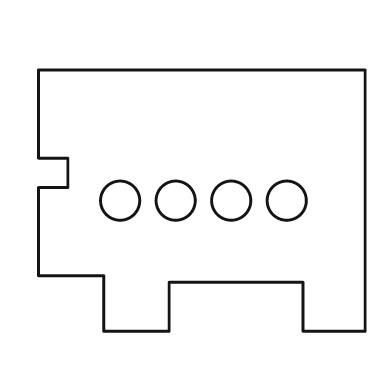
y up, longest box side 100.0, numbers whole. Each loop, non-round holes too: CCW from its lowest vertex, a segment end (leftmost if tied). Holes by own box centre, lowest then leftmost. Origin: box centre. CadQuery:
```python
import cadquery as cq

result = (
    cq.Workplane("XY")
    .moveTo(-30.0, -40.0)
    .lineTo(-10.0, -40.0)
    .lineTo(-10.0, -25.0)
    .lineTo(31.0, -25.0)
    .lineTo(31.0, -40.0)
    .lineTo(50.0, -40.0)
    .lineTo(50.0, 40.0)
    .lineTo(-50.0, 40.0)
    .lineTo(-50.0, 13.0)
    .lineTo(-41.0, 13.0)
    .lineTo(-41.0, 4.0)
    .lineTo(-50.0, 4.0)
    .lineTo(-50.0, -23.0)
    .lineTo(-30.0, -23.0)
    .close()
    .moveTo(-25.0, 0.0)
    .circle(6.0)
    .moveTo(-8.0, 0.0)
    .circle(6.0)
    .moveTo(9.0, 0.0)
    .circle(6.0)
    .moveTo(26.0, 0.0)
    .circle(6.0)
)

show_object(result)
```